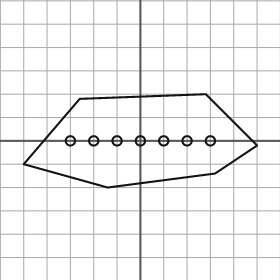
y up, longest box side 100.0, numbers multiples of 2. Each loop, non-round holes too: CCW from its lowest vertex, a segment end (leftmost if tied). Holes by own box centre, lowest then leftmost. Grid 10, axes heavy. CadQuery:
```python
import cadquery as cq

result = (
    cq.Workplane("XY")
    .moveTo(-14.0, -20.0)
    .lineTo(32.0, -14.0)
    .lineTo(50.0, -2.0)
    .lineTo(28.0, 20.0)
    .lineTo(-26.0, 18.0)
    .lineTo(-50.0, -10.0)
    .close()
    .moveTo(-30.0, 0.0)
    .circle(2.0)
    .moveTo(-20.0, 0.0)
    .circle(2.0)
    .moveTo(-10.0, 0.0)
    .circle(2.0)
    .moveTo(0.0, 0.0)
    .circle(2.0)
    .moveTo(10.0, 0.0)
    .circle(2.0)
    .moveTo(20.0, 0.0)
    .circle(2.0)
    .moveTo(30.0, 0.0)
    .circle(2.0)
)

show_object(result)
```